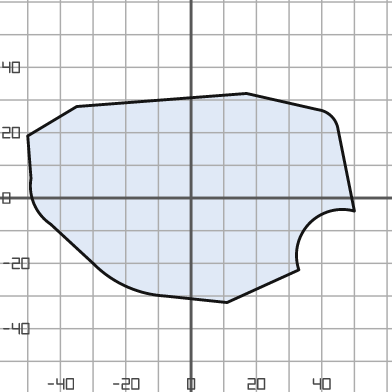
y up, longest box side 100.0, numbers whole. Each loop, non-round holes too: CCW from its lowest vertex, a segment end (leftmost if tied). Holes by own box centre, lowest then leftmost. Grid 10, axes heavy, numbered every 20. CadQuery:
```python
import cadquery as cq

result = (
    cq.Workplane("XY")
    .moveTo(11.0, -32.0)
    .lineTo(33.0, -22.0)
    .threePointArc((36.0, -8.0), (50.0, -4.0))
    .lineTo(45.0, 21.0)
    .threePointArc((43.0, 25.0), (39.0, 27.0))
    .lineTo(17.0, 32.0)
    .lineTo(-35.0, 28.0)
    .lineTo(-50.0, 19.0)
    .lineTo(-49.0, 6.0)
    .threePointArc((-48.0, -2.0), (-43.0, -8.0))
    .lineTo(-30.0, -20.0)
    .threePointArc((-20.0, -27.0), (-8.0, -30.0))
    .close()
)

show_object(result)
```